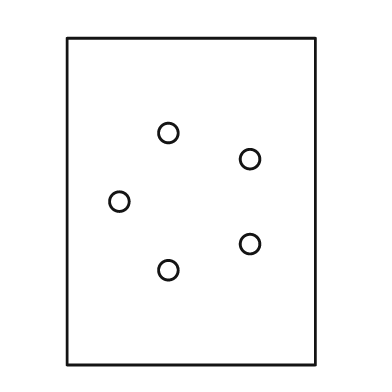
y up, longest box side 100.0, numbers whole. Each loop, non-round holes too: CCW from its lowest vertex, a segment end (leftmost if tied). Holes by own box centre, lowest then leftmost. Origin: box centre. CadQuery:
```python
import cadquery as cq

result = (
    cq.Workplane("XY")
    .moveTo(-38.0, -50.0)
    .lineTo(38.0, -50.0)
    .lineTo(38.0, 50.0)
    .lineTo(-38.0, 50.0)
    .close()
    .moveTo(-7.0, -21.0)
    .circle(3.0)
    .moveTo(18.0, -13.0)
    .circle(3.0)
    .moveTo(-22.0, 0.0)
    .circle(3.0)
    .moveTo(18.0, 13.0)
    .circle(3.0)
    .moveTo(-7.0, 21.0)
    .circle(3.0)
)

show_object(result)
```